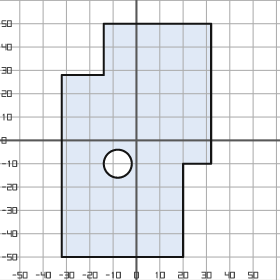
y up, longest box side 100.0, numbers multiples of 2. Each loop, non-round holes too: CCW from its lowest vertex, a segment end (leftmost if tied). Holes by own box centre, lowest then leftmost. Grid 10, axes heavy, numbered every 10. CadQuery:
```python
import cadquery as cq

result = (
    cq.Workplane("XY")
    .moveTo(-32.0, -50.0)
    .lineTo(20.0, -50.0)
    .lineTo(20.0, -10.0)
    .lineTo(32.0, -10.0)
    .lineTo(32.0, 50.0)
    .lineTo(-14.0, 50.0)
    .lineTo(-14.0, 28.0)
    .lineTo(-32.0, 28.0)
    .close()
    .moveTo(-8.0, -10.0)
    .circle(6.0)
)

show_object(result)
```